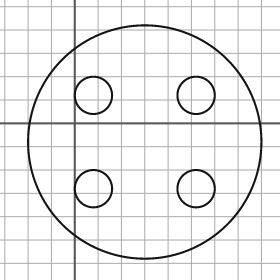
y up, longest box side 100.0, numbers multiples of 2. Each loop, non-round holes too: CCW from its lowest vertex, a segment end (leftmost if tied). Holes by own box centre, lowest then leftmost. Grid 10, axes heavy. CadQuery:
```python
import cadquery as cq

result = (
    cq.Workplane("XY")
    .moveTo(30.0, -8.0)
    .circle(50.0)
    .moveTo(8.0, -28.0)
    .circle(8.0)
    .moveTo(52.0, -28.0)
    .circle(8.0)
    .moveTo(8.0, 12.0)
    .circle(8.0)
    .moveTo(52.0, 12.0)
    .circle(8.0)
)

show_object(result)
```